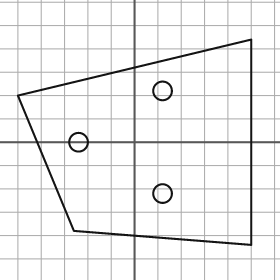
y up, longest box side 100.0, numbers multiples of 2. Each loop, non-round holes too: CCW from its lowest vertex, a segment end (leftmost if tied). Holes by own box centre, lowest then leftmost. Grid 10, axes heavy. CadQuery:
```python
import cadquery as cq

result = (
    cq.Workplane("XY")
    .moveTo(50.0, -44.0)
    .lineTo(50.0, 44.0)
    .lineTo(-50.0, 20.0)
    .lineTo(-26.0, -38.0)
    .close()
    .moveTo(12.0, -22.0)
    .circle(4.0)
    .moveTo(-24.0, 0.0)
    .circle(4.0)
    .moveTo(12.0, 22.0)
    .circle(4.0)
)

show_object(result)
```